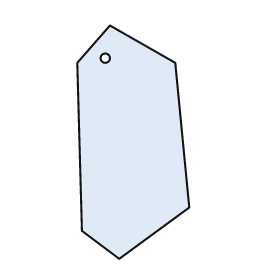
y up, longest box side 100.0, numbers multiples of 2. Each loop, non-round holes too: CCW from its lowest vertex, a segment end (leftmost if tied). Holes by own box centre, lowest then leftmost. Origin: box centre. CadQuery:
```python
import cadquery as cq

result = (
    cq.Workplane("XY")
    .moveTo(-6.0, -50.0)
    .lineTo(24.0, -28.0)
    .lineTo(18.0, 34.0)
    .lineTo(-10.0, 50.0)
    .lineTo(-24.0, 34.0)
    .lineTo(-22.0, -38.0)
    .close()
    .moveTo(-12.0, 36.0)
    .circle(2.0)
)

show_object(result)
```